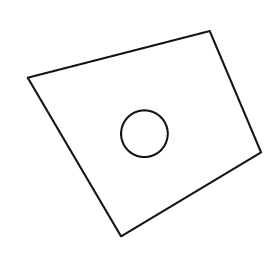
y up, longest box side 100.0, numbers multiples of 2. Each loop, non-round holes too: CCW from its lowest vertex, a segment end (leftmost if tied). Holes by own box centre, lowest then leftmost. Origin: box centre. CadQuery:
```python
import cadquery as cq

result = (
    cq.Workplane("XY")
    .moveTo(-10.0, -44.0)
    .lineTo(50.0, -8.0)
    .lineTo(28.0, 44.0)
    .lineTo(-50.0, 24.0)
    .close()
    .moveTo(0.0, 0.0)
    .circle(10.0)
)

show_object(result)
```